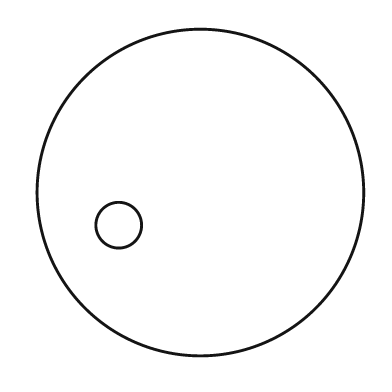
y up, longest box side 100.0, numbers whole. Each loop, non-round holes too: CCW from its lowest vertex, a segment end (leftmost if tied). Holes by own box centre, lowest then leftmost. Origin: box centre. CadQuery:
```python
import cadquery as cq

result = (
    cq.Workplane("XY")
    .moveTo(0.0, 0.0)
    .circle(50.0)
    .moveTo(-25.0, -10.0)
    .circle(7.0)
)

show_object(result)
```